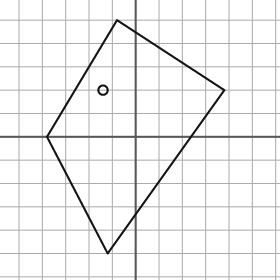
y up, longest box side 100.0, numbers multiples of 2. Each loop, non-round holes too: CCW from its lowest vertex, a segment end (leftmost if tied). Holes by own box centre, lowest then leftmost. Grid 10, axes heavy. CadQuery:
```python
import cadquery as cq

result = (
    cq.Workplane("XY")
    .moveTo(-12.0, -50.0)
    .lineTo(38.0, 20.0)
    .lineTo(-8.0, 50.0)
    .lineTo(-38.0, 0.0)
    .close()
    .moveTo(-14.0, 20.0)
    .circle(2.0)
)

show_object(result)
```